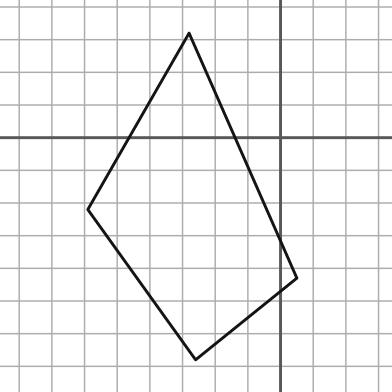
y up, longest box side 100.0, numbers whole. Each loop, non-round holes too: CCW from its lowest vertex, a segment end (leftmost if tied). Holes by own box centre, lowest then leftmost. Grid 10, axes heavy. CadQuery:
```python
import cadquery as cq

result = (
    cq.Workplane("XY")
    .moveTo(-26.0, -68.0)
    .lineTo(5.0, -43.0)
    .lineTo(-28.0, 32.0)
    .lineTo(-59.0, -22.0)
    .close()
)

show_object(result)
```